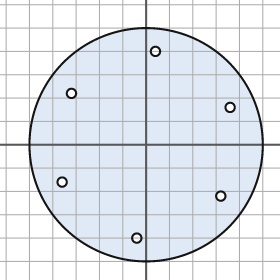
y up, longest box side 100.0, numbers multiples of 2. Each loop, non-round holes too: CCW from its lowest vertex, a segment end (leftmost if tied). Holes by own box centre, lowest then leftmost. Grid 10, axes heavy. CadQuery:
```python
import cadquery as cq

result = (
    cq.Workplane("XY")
    .moveTo(0.0, 0.0)
    .circle(50.0)
    .moveTo(-4.0, -40.0)
    .circle(2.0)
    .moveTo(32.0, -22.0)
    .circle(2.0)
    .moveTo(-36.0, -16.0)
    .circle(2.0)
    .moveTo(36.0, 16.0)
    .circle(2.0)
    .moveTo(-32.0, 22.0)
    .circle(2.0)
    .moveTo(4.0, 40.0)
    .circle(2.0)
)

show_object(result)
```